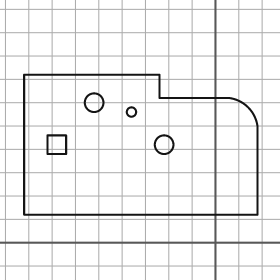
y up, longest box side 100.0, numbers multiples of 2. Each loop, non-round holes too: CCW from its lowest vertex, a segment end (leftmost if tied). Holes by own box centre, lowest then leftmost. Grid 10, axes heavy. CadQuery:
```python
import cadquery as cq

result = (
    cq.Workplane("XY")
    .moveTo(-82.0, 12.0)
    .lineTo(18.0, 12.0)
    .lineTo(18.0, 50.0)
    .threePointArc((14.0, 58.0), (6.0, 62.0))
    .lineTo(-24.0, 62.0)
    .lineTo(-24.0, 72.0)
    .lineTo(-82.0, 72.0)
    .close()
    .moveTo(-72.0, 38.0)
    .lineTo(-64.0, 38.0)
    .lineTo(-64.0, 46.0)
    .lineTo(-72.0, 46.0)
    .close()
    .moveTo(-22.0, 42.0)
    .circle(4.0)
    .moveTo(-36.0, 56.0)
    .circle(2.0)
    .moveTo(-52.0, 60.0)
    .circle(4.0)
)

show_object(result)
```